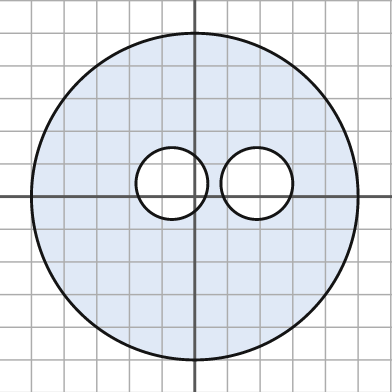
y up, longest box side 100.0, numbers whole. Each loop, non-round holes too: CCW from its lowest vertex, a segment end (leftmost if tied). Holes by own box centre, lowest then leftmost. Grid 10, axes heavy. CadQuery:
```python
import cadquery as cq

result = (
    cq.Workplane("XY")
    .moveTo(0.0, 0.0)
    .circle(50.0)
    .moveTo(-7.0, 4.0)
    .circle(11.0)
    .moveTo(19.0, 4.0)
    .circle(11.0)
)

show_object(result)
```